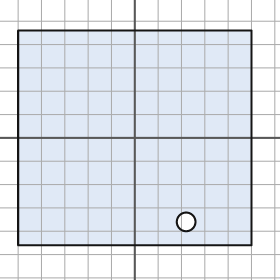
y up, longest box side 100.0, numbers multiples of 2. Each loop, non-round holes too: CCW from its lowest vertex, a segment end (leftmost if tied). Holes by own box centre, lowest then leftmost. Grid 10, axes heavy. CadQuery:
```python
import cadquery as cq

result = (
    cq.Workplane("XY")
    .moveTo(-50.0, -46.0)
    .lineTo(50.0, -46.0)
    .lineTo(50.0, 46.0)
    .lineTo(-50.0, 46.0)
    .close()
    .moveTo(22.0, -36.0)
    .circle(4.0)
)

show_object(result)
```